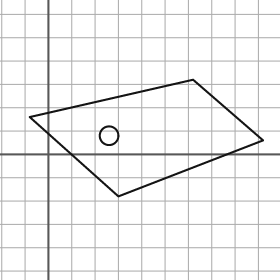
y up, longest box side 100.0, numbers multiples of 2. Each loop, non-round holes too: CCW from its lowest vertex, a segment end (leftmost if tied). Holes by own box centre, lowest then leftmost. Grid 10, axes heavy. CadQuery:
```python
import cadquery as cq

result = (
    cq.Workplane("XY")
    .moveTo(30.0, -18.0)
    .lineTo(92.0, 6.0)
    .lineTo(62.0, 32.0)
    .lineTo(-8.0, 16.0)
    .close()
    .moveTo(26.0, 8.0)
    .circle(4.0)
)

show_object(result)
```